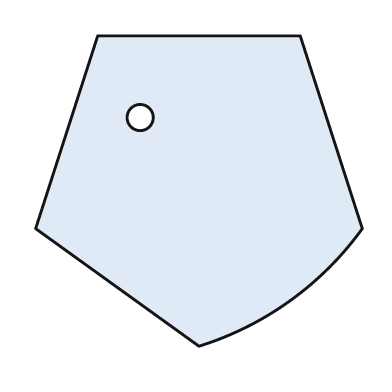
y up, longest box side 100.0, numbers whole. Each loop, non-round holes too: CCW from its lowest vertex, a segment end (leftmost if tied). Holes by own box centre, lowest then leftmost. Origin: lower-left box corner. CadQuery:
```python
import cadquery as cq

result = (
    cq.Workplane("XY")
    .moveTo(50.0, 0.0)
    .threePointArc((78.0, 14.0), (100.0, 36.0))
    .lineTo(81.0, 95.0)
    .lineTo(19.0, 95.0)
    .lineTo(0.0, 36.0)
    .close()
    .moveTo(32.0, 70.0)
    .circle(4.0)
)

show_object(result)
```